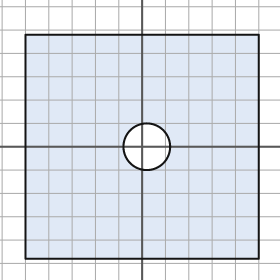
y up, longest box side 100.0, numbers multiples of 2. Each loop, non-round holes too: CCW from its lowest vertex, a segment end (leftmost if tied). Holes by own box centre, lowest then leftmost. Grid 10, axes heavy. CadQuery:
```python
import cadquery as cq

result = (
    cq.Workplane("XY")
    .moveTo(-50.0, -48.0)
    .lineTo(50.0, -48.0)
    .lineTo(50.0, 48.0)
    .lineTo(-50.0, 48.0)
    .close()
    .moveTo(2.0, 0.0)
    .circle(10.0)
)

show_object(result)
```